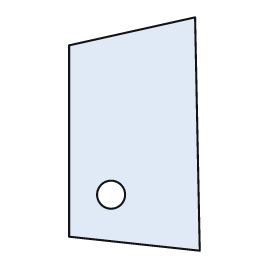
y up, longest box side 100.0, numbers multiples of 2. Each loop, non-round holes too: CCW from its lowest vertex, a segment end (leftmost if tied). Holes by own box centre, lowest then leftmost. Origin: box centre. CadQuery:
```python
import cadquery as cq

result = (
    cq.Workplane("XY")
    .moveTo(28.0, -50.0)
    .lineTo(26.0, 50.0)
    .lineTo(-28.0, 38.0)
    .lineTo(-28.0, -44.0)
    .close()
    .moveTo(-10.0, -26.0)
    .circle(6.0)
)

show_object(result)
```